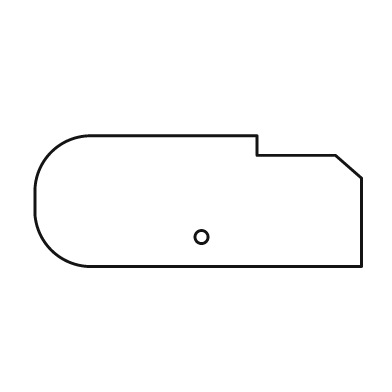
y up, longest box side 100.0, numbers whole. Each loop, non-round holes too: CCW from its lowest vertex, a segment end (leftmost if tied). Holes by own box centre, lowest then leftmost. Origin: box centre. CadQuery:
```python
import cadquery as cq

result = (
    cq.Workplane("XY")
    .moveTo(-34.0, -20.0)
    .lineTo(50.0, -20.0)
    .lineTo(50.0, 7.0)
    .lineTo(42.0, 14.0)
    .lineTo(18.0, 14.0)
    .lineTo(18.0, 20.0)
    .lineTo(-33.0, 20.0)
    .threePointArc((-45.0, 15.0), (-50.0, 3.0))
    .lineTo(-50.0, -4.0)
    .threePointArc((-45.0, -15.0), (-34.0, -20.0))
    .close()
    .moveTo(1.0, -11.0)
    .circle(2.0)
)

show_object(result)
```